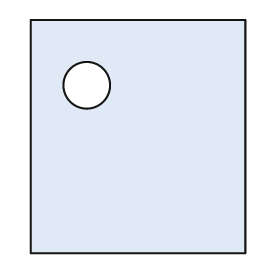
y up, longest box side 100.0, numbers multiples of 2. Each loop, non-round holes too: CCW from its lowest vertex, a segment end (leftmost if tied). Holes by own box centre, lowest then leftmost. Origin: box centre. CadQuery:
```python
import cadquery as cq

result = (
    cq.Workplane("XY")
    .moveTo(-46.0, -50.0)
    .lineTo(46.0, -50.0)
    .lineTo(46.0, 50.0)
    .lineTo(-46.0, 50.0)
    .close()
    .moveTo(-22.0, 22.0)
    .circle(10.0)
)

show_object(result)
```